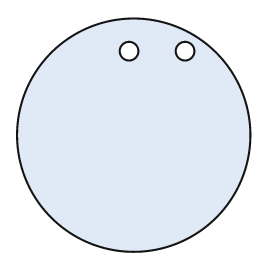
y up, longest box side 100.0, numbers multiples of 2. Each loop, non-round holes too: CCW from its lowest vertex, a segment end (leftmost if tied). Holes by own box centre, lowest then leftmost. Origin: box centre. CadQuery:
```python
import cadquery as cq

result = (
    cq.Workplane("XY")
    .moveTo(0.0, 0.0)
    .circle(50.0)
    .moveTo(-2.0, 36.0)
    .circle(4.0)
    .moveTo(22.0, 36.0)
    .circle(4.0)
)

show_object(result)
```